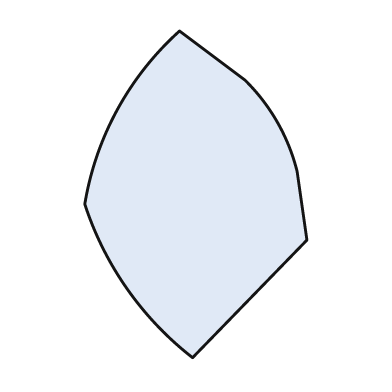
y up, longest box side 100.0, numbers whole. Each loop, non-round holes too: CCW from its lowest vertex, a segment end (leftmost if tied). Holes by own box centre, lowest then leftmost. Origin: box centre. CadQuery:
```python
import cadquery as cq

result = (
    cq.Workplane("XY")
    .moveTo(-1.0, -50.0)
    .lineTo(34.0, -14.0)
    .lineTo(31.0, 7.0)
    .threePointArc((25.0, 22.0), (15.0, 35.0))
    .lineTo(-5.0, 50.0)
    .threePointArc((-24.0, 26.0), (-34.0, -3.0))
    .threePointArc((-21.0, -29.0), (-1.0, -50.0))
    .close()
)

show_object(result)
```